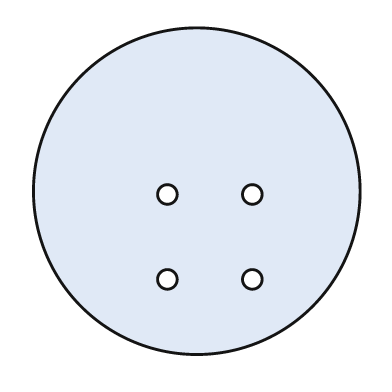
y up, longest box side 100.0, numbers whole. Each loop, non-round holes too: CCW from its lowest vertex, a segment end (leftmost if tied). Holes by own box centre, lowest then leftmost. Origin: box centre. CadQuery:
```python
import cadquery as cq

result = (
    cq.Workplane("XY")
    .moveTo(0.0, 0.0)
    .circle(50.0)
    .moveTo(-9.0, -27.0)
    .circle(3.0)
    .moveTo(17.0, -27.0)
    .circle(3.0)
    .moveTo(-9.0, -1.0)
    .circle(3.0)
    .moveTo(17.0, -1.0)
    .circle(3.0)
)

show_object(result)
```